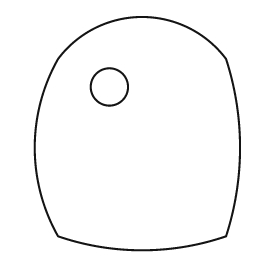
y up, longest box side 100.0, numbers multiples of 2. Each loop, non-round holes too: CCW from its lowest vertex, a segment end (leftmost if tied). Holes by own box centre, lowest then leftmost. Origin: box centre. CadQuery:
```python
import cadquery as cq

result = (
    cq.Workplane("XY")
    .moveTo(-34.0, -44.0)
    .threePointArc((2.0, -50.0), (38.0, -44.0))
    .threePointArc((44.0, -6.0), (38.0, 32.0))
    .threePointArc((2.0, 50.0), (-34.0, 32.0))
    .threePointArc((-44.0, -6.0), (-34.0, -44.0))
    .close()
    .moveTo(-12.0, 20.0)
    .circle(8.0)
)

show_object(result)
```